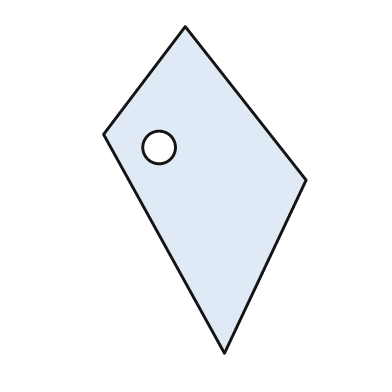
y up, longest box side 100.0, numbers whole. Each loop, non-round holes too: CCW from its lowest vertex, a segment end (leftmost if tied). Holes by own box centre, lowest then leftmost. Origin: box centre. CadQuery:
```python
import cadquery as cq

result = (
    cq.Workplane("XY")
    .moveTo(6.0, -50.0)
    .lineTo(31.0, 3.0)
    .lineTo(-6.0, 50.0)
    .lineTo(-31.0, 17.0)
    .close()
    .moveTo(-14.0, 13.0)
    .circle(5.0)
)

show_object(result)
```